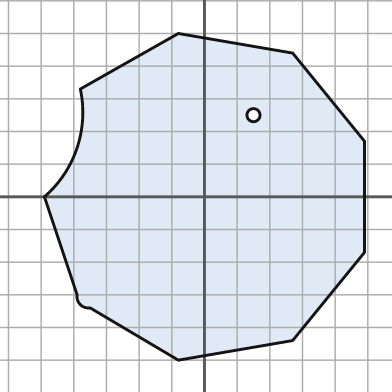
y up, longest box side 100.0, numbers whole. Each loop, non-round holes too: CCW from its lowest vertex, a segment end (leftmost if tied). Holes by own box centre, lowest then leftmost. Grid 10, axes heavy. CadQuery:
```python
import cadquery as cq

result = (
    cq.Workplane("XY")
    .moveTo(-8.0, -50.0)
    .lineTo(27.0, -44.0)
    .lineTo(49.0, -17.0)
    .lineTo(49.0, 17.0)
    .lineTo(27.0, 44.0)
    .lineTo(-8.0, 50.0)
    .lineTo(-38.0, 33.0)
    .threePointArc((-39.0, 15.0), (-49.0, 0.0))
    .lineTo(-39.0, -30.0)
    .threePointArc((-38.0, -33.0), (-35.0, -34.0))
    .close()
    .moveTo(15.0, 25.0)
    .circle(2.0)
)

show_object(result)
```